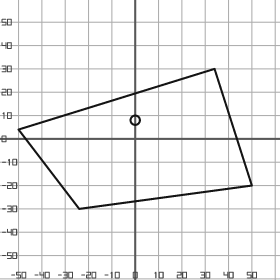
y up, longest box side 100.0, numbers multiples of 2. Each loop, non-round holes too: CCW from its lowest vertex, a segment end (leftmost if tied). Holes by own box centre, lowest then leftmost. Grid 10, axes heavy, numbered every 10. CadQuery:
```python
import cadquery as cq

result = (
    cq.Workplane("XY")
    .moveTo(-24.0, -30.0)
    .lineTo(50.0, -20.0)
    .lineTo(34.0, 30.0)
    .lineTo(-50.0, 4.0)
    .close()
    .moveTo(0.0, 8.0)
    .circle(2.0)
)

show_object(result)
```